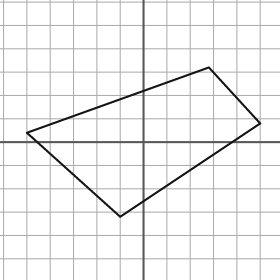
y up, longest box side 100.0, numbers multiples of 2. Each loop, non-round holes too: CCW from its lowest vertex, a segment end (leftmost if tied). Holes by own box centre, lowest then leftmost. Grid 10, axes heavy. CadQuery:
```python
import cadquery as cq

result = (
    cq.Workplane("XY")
    .moveTo(-10.0, -32.0)
    .lineTo(50.0, 8.0)
    .lineTo(28.0, 32.0)
    .lineTo(-50.0, 4.0)
    .close()
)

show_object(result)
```